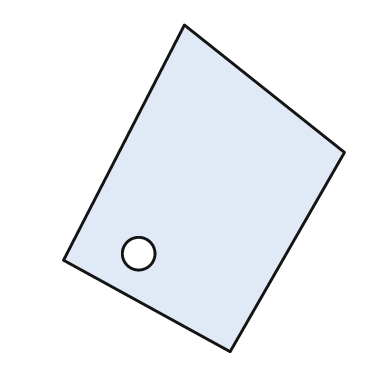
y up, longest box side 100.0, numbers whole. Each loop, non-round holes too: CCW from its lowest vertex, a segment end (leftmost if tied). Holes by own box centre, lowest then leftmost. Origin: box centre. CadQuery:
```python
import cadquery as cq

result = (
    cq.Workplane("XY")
    .moveTo(8.0, -50.0)
    .lineTo(43.0, 11.0)
    .lineTo(-6.0, 50.0)
    .lineTo(-43.0, -22.0)
    .close()
    .moveTo(-20.0, -20.0)
    .circle(5.0)
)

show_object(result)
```